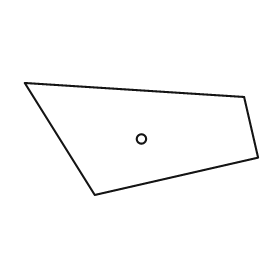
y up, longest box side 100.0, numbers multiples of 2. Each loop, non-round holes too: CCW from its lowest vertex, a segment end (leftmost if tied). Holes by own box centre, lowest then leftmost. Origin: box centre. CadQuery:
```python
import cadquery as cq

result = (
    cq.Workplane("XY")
    .moveTo(-20.0, -24.0)
    .lineTo(50.0, -8.0)
    .lineTo(44.0, 18.0)
    .lineTo(-50.0, 24.0)
    .close()
    .moveTo(0.0, 0.0)
    .circle(2.0)
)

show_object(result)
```